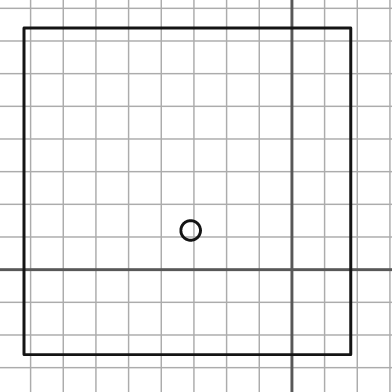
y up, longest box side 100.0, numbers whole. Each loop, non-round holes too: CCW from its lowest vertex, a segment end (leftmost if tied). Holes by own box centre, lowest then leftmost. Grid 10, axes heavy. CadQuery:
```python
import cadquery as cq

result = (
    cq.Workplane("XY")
    .moveTo(-82.0, -26.0)
    .lineTo(18.0, -26.0)
    .lineTo(18.0, 74.0)
    .lineTo(-82.0, 74.0)
    .close()
    .moveTo(-31.0, 12.0)
    .circle(3.0)
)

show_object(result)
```